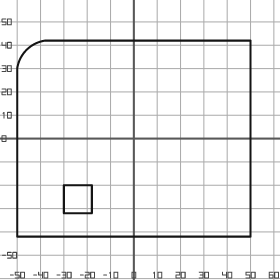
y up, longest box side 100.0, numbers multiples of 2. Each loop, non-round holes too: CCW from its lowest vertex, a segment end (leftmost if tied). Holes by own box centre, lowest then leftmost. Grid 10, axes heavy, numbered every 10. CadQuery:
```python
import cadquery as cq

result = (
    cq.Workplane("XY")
    .moveTo(-50.0, -42.0)
    .lineTo(50.0, -42.0)
    .lineTo(50.0, 42.0)
    .lineTo(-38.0, 42.0)
    .threePointArc((-46.0, 38.0), (-50.0, 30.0))
    .close()
    .moveTo(-30.0, -32.0)
    .lineTo(-18.0, -32.0)
    .lineTo(-18.0, -20.0)
    .lineTo(-30.0, -20.0)
    .close()
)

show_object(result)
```